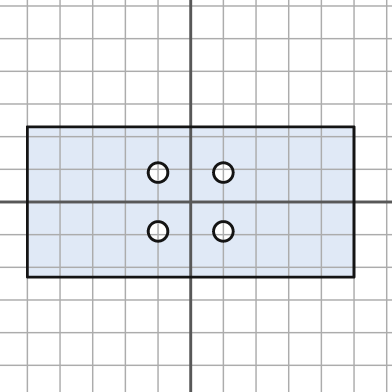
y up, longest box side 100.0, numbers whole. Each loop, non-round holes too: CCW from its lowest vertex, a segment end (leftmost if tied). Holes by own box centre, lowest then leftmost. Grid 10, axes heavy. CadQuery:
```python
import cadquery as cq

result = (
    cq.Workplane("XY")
    .moveTo(-50.0, -23.0)
    .lineTo(50.0, -23.0)
    .lineTo(50.0, 23.0)
    .lineTo(-50.0, 23.0)
    .close()
    .moveTo(-10.0, -9.0)
    .circle(3.0)
    .moveTo(10.0, -9.0)
    .circle(3.0)
    .moveTo(-10.0, 9.0)
    .circle(3.0)
    .moveTo(10.0, 9.0)
    .circle(3.0)
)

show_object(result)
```